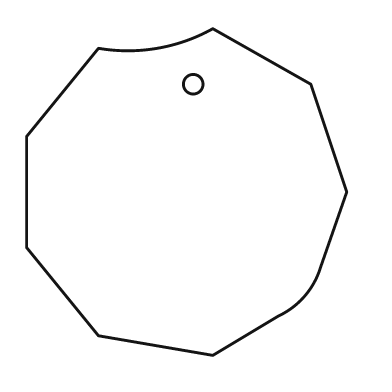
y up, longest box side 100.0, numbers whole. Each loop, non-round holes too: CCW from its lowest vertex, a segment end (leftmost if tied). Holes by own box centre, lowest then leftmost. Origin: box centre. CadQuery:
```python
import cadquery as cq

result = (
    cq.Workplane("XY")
    .moveTo(8.0, -50.0)
    .lineTo(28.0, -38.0)
    .threePointArc((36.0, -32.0), (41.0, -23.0))
    .lineTo(49.0, 0.0)
    .lineTo(38.0, 33.0)
    .lineTo(8.0, 50.0)
    .threePointArc((-9.0, 44.0), (-27.0, 44.0))
    .lineTo(-49.0, 17.0)
    .lineTo(-49.0, -17.0)
    .lineTo(-27.0, -44.0)
    .close()
    .moveTo(2.0, 33.0)
    .circle(3.0)
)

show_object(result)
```